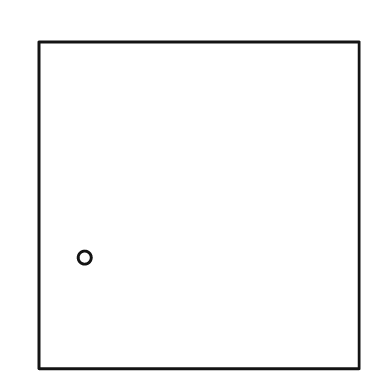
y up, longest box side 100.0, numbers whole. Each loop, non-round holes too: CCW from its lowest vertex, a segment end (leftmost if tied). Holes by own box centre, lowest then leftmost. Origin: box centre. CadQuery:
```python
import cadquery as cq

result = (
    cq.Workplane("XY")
    .moveTo(-49.0, -50.0)
    .lineTo(49.0, -50.0)
    .lineTo(49.0, 50.0)
    .lineTo(-49.0, 50.0)
    .close()
    .moveTo(-35.0, -16.0)
    .circle(2.0)
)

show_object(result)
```